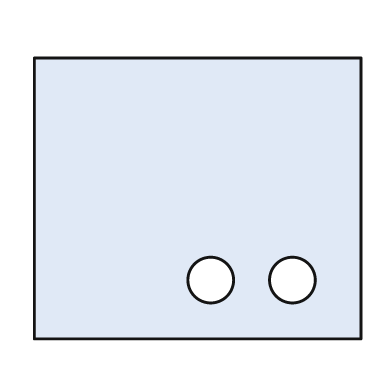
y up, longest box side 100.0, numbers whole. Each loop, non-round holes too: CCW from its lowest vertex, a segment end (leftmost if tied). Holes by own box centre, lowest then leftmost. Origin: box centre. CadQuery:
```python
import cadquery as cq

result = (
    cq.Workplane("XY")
    .moveTo(-50.0, -43.0)
    .lineTo(50.0, -43.0)
    .lineTo(50.0, 43.0)
    .lineTo(-50.0, 43.0)
    .close()
    .moveTo(4.0, -25.0)
    .circle(7.0)
    .moveTo(29.0, -25.0)
    .circle(7.0)
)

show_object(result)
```